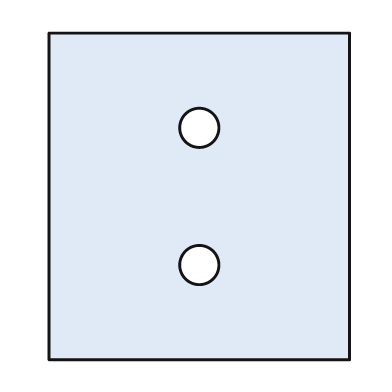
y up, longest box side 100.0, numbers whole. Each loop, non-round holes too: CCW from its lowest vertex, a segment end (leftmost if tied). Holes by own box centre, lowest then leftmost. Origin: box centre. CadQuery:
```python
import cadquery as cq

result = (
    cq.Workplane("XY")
    .moveTo(-46.0, -50.0)
    .lineTo(46.0, -50.0)
    .lineTo(46.0, 50.0)
    .lineTo(-46.0, 50.0)
    .close()
    .moveTo(0.0, -21.0)
    .circle(6.0)
    .moveTo(0.0, 21.0)
    .circle(6.0)
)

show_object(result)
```